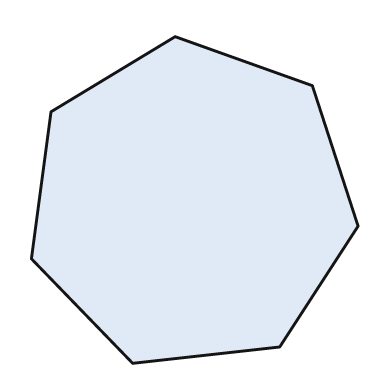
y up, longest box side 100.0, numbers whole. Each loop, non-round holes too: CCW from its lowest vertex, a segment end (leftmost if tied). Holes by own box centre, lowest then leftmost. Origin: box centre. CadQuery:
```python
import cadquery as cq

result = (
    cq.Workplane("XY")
    .moveTo(-19.0, -50.0)
    .lineTo(26.0, -45.0)
    .lineTo(50.0, -8.0)
    .lineTo(36.0, 35.0)
    .lineTo(-6.0, 50.0)
    .lineTo(-44.0, 27.0)
    .lineTo(-50.0, -18.0)
    .close()
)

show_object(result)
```